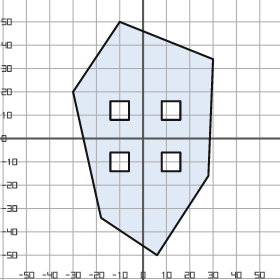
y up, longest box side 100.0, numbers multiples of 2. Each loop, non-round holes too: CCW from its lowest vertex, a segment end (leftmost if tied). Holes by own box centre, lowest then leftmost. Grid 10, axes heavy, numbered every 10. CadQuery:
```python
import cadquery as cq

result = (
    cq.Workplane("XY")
    .moveTo(6.0, -50.0)
    .lineTo(28.0, -16.0)
    .lineTo(30.0, 34.0)
    .lineTo(-10.0, 50.0)
    .lineTo(-30.0, 20.0)
    .lineTo(-18.0, -34.0)
    .close()
    .moveTo(-14.0, -14.0)
    .lineTo(-6.0, -14.0)
    .lineTo(-6.0, -6.0)
    .lineTo(-14.0, -6.0)
    .close()
    .moveTo(8.0, -14.0)
    .lineTo(16.0, -14.0)
    .lineTo(16.0, -6.0)
    .lineTo(8.0, -6.0)
    .close()
    .moveTo(-14.0, 8.0)
    .lineTo(-6.0, 8.0)
    .lineTo(-6.0, 16.0)
    .lineTo(-14.0, 16.0)
    .close()
    .moveTo(8.0, 8.0)
    .lineTo(16.0, 8.0)
    .lineTo(16.0, 16.0)
    .lineTo(8.0, 16.0)
    .close()
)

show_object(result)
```